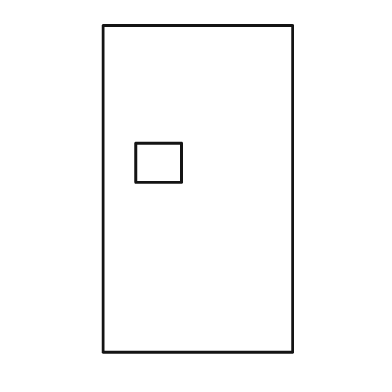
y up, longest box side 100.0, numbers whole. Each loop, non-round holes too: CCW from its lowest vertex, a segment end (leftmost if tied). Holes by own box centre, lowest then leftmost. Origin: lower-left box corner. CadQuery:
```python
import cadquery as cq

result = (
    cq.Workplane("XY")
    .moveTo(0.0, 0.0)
    .lineTo(58.0, 0.0)
    .lineTo(58.0, 100.0)
    .lineTo(0.0, 100.0)
    .close()
    .moveTo(10.0, 52.0)
    .lineTo(24.0, 52.0)
    .lineTo(24.0, 64.0)
    .lineTo(10.0, 64.0)
    .close()
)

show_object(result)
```